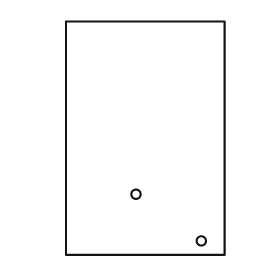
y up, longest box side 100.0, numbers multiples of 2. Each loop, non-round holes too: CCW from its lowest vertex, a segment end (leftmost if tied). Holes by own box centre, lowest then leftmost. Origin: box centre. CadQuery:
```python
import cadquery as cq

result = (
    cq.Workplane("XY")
    .moveTo(-34.0, -50.0)
    .lineTo(34.0, -50.0)
    .lineTo(34.0, 50.0)
    .lineTo(-34.0, 50.0)
    .close()
    .moveTo(24.0, -44.0)
    .circle(2.0)
    .moveTo(-4.0, -24.0)
    .circle(2.0)
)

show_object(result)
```